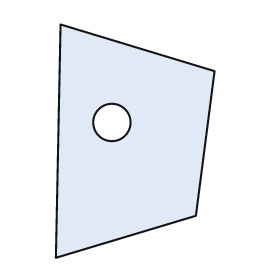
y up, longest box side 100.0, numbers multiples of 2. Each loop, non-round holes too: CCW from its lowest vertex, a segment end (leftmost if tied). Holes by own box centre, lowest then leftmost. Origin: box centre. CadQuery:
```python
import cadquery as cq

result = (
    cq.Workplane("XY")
    .moveTo(-34.0, -50.0)
    .lineTo(26.0, -32.0)
    .lineTo(34.0, 30.0)
    .lineTo(-32.0, 50.0)
    .close()
    .moveTo(-10.0, 8.0)
    .circle(8.0)
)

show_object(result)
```